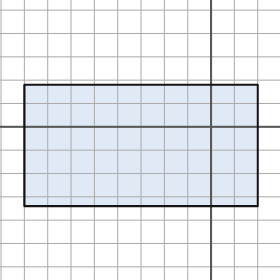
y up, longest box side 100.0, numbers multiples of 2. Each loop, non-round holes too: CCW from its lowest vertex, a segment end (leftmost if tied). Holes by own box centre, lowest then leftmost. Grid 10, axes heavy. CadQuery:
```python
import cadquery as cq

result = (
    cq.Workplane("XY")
    .moveTo(-80.0, -34.0)
    .lineTo(20.0, -34.0)
    .lineTo(20.0, 18.0)
    .lineTo(-80.0, 18.0)
    .close()
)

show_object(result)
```